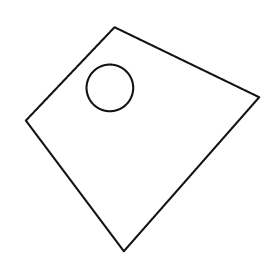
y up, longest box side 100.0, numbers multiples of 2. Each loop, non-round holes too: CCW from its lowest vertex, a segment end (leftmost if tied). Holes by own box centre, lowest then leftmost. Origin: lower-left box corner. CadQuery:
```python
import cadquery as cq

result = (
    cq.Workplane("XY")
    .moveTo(42.0, 0.0)
    .lineTo(100.0, 66.0)
    .lineTo(38.0, 96.0)
    .lineTo(0.0, 56.0)
    .close()
    .moveTo(36.0, 70.0)
    .circle(10.0)
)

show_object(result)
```